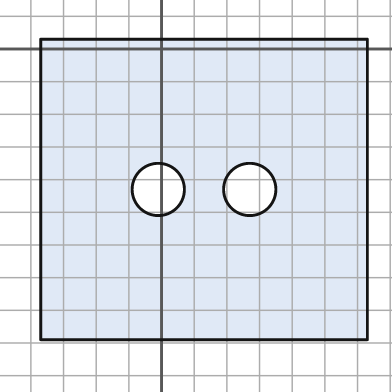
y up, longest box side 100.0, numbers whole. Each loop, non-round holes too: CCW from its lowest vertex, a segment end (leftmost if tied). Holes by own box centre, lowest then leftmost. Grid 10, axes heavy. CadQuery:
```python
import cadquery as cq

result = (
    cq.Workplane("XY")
    .moveTo(-37.0, -89.0)
    .lineTo(63.0, -89.0)
    .lineTo(63.0, 3.0)
    .lineTo(-37.0, 3.0)
    .close()
    .moveTo(-1.0, -43.0)
    .circle(8.0)
    .moveTo(27.0, -43.0)
    .circle(8.0)
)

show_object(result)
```